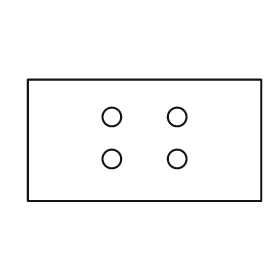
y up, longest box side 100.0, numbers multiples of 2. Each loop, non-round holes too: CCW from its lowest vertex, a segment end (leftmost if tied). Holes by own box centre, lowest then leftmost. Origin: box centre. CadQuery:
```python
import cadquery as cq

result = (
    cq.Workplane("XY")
    .moveTo(-50.0, -26.0)
    .lineTo(50.0, -26.0)
    .lineTo(50.0, 26.0)
    .lineTo(-50.0, 26.0)
    .close()
    .moveTo(-14.0, -8.0)
    .circle(4.0)
    .moveTo(14.0, -8.0)
    .circle(4.0)
    .moveTo(-14.0, 10.0)
    .circle(4.0)
    .moveTo(14.0, 10.0)
    .circle(4.0)
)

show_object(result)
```